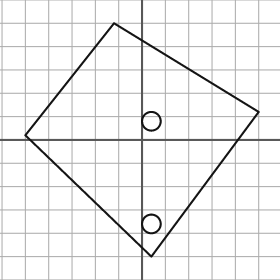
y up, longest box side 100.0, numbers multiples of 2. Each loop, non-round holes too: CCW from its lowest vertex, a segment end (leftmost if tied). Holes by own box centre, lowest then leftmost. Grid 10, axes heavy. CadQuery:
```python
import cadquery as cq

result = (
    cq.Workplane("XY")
    .moveTo(4.0, -50.0)
    .lineTo(50.0, 12.0)
    .lineTo(-12.0, 50.0)
    .lineTo(-50.0, 2.0)
    .close()
    .moveTo(4.0, -36.0)
    .circle(4.0)
    .moveTo(4.0, 8.0)
    .circle(4.0)
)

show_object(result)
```